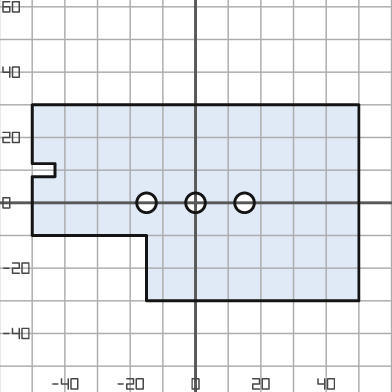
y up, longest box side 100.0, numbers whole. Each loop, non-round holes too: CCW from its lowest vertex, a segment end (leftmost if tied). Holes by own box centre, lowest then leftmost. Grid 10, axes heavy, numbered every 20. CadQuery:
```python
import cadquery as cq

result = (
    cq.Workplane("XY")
    .moveTo(-15.0, -30.0)
    .lineTo(50.0, -30.0)
    .lineTo(50.0, 30.0)
    .lineTo(-50.0, 30.0)
    .lineTo(-50.0, 12.0)
    .lineTo(-43.0, 12.0)
    .lineTo(-43.0, 8.0)
    .lineTo(-50.0, 8.0)
    .lineTo(-50.0, -10.0)
    .lineTo(-15.0, -10.0)
    .close()
    .moveTo(-15.0, 0.0)
    .circle(3.0)
    .moveTo(0.0, 0.0)
    .circle(3.0)
    .moveTo(15.0, 0.0)
    .circle(3.0)
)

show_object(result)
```